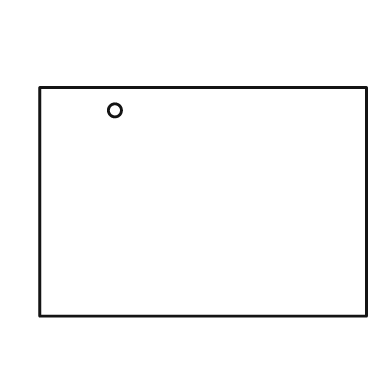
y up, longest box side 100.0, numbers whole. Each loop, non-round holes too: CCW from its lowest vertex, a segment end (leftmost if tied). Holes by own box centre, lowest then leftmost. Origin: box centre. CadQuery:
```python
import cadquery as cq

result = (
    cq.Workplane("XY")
    .moveTo(-50.0, -35.0)
    .lineTo(50.0, -35.0)
    .lineTo(50.0, 35.0)
    .lineTo(-50.0, 35.0)
    .close()
    .moveTo(-27.0, 28.0)
    .circle(2.0)
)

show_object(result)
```